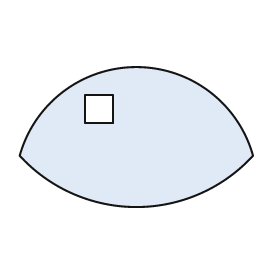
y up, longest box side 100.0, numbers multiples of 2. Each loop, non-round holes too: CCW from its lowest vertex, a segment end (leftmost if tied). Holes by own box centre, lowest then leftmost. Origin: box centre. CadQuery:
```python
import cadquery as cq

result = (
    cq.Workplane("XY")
    .moveTo(-50.0, -8.0)
    .threePointArc((0.0, -30.0), (50.0, -8.0))
    .threePointArc((0.0, 30.0), (-50.0, -8.0))
    .close()
    .moveTo(-22.0, 6.0)
    .lineTo(-10.0, 6.0)
    .lineTo(-10.0, 18.0)
    .lineTo(-22.0, 18.0)
    .close()
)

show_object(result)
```